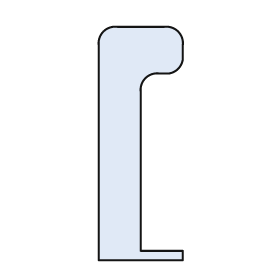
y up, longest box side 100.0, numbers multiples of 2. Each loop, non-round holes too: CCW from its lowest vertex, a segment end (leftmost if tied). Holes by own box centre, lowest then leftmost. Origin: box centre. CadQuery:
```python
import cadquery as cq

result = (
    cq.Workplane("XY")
    .moveTo(-18.0, -50.0)
    .lineTo(18.0, -50.0)
    .lineTo(18.0, -46.0)
    .lineTo(0.0, -46.0)
    .lineTo(0.0, 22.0)
    .threePointArc((2.0, 28.0), (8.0, 30.0))
    .lineTo(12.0, 30.0)
    .threePointArc((16.0, 32.0), (18.0, 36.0))
    .lineTo(18.0, 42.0)
    .threePointArc((16.0, 48.0), (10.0, 50.0))
    .lineTo(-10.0, 50.0)
    .threePointArc((-16.0, 48.0), (-18.0, 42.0))
    .close()
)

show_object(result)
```